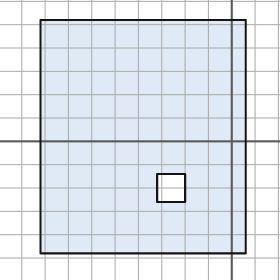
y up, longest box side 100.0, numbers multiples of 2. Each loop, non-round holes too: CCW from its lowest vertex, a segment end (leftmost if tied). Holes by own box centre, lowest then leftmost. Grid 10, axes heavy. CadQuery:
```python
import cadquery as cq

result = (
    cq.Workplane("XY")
    .moveTo(-82.0, -48.0)
    .lineTo(6.0, -48.0)
    .lineTo(6.0, 52.0)
    .lineTo(-82.0, 52.0)
    .close()
    .moveTo(-32.0, -26.0)
    .lineTo(-20.0, -26.0)
    .lineTo(-20.0, -14.0)
    .lineTo(-32.0, -14.0)
    .close()
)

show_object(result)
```